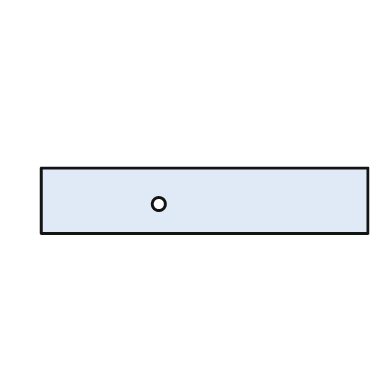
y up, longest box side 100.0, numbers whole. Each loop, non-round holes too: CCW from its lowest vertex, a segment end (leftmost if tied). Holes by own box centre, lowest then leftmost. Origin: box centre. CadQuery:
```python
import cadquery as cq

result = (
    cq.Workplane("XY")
    .moveTo(-50.0, -10.0)
    .lineTo(50.0, -10.0)
    .lineTo(50.0, 10.0)
    .lineTo(-50.0, 10.0)
    .close()
    .moveTo(-14.0, -1.0)
    .circle(2.0)
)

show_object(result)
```